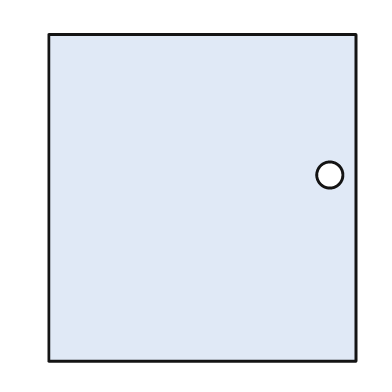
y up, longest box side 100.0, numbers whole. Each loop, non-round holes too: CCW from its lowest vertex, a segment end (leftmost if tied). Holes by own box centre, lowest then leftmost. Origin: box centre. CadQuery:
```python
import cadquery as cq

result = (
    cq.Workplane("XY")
    .moveTo(-47.0, -50.0)
    .lineTo(47.0, -50.0)
    .lineTo(47.0, 50.0)
    .lineTo(-47.0, 50.0)
    .close()
    .moveTo(39.0, 7.0)
    .circle(4.0)
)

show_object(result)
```